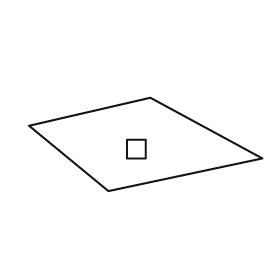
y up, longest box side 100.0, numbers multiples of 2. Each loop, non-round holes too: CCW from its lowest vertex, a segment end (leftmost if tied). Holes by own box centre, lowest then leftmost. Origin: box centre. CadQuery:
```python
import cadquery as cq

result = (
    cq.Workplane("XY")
    .moveTo(-16.0, -20.0)
    .lineTo(50.0, -6.0)
    .lineTo(2.0, 20.0)
    .lineTo(-50.0, 8.0)
    .close()
    .moveTo(-8.0, -6.0)
    .lineTo(0.0, -6.0)
    .lineTo(0.0, 2.0)
    .lineTo(-8.0, 2.0)
    .close()
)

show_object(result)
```